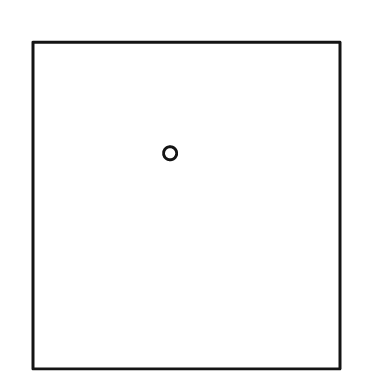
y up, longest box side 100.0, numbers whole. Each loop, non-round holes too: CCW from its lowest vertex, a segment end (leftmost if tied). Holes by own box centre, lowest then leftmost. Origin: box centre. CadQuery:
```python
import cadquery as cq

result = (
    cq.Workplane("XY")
    .moveTo(-47.0, -50.0)
    .lineTo(47.0, -50.0)
    .lineTo(47.0, 50.0)
    .lineTo(-47.0, 50.0)
    .close()
    .moveTo(-5.0, 16.0)
    .circle(2.0)
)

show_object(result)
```